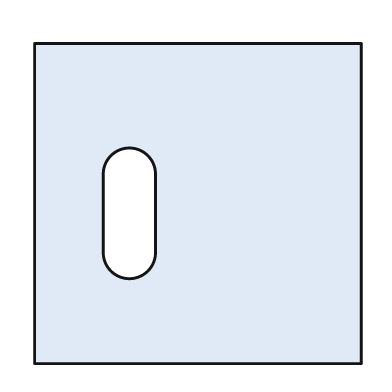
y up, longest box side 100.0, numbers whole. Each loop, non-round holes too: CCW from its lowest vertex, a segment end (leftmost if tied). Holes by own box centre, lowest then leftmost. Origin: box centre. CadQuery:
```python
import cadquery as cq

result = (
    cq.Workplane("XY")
    .moveTo(-50.0, -49.0)
    .lineTo(50.0, -49.0)
    .lineTo(50.0, 49.0)
    .lineTo(-50.0, 49.0)
    .close()
    .moveTo(-29.0, -15.0)
    .threePointArc((-21.0, -23.0), (-13.0, -15.0))
    .lineTo(-13.0, 9.0)
    .threePointArc((-21.0, 17.0), (-29.0, 9.0))
    .close()
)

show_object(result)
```